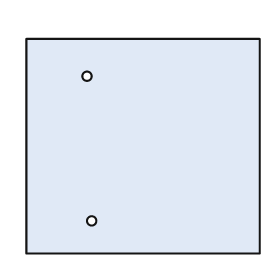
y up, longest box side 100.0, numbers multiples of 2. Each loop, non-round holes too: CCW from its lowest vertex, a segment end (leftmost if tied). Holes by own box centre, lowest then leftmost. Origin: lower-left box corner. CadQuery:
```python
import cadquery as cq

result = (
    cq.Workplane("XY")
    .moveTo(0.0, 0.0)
    .lineTo(100.0, 0.0)
    .lineTo(100.0, 92.0)
    .lineTo(0.0, 92.0)
    .close()
    .moveTo(28.0, 14.0)
    .circle(2.0)
    .moveTo(26.0, 76.0)
    .circle(2.0)
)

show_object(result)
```